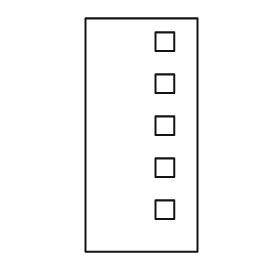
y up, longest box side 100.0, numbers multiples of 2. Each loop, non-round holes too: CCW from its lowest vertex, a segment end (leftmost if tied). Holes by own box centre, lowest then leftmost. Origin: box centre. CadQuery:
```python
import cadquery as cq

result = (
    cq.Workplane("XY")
    .moveTo(-24.0, -50.0)
    .lineTo(24.0, -50.0)
    .lineTo(24.0, 50.0)
    .lineTo(-24.0, 50.0)
    .close()
    .moveTo(6.0, -36.0)
    .lineTo(14.0, -36.0)
    .lineTo(14.0, -28.0)
    .lineTo(6.0, -28.0)
    .close()
    .moveTo(6.0, -18.0)
    .lineTo(14.0, -18.0)
    .lineTo(14.0, -10.0)
    .lineTo(6.0, -10.0)
    .close()
    .moveTo(6.0, 0.0)
    .lineTo(14.0, 0.0)
    .lineTo(14.0, 8.0)
    .lineTo(6.0, 8.0)
    .close()
    .moveTo(6.0, 18.0)
    .lineTo(14.0, 18.0)
    .lineTo(14.0, 26.0)
    .lineTo(6.0, 26.0)
    .close()
    .moveTo(6.0, 36.0)
    .lineTo(14.0, 36.0)
    .lineTo(14.0, 44.0)
    .lineTo(6.0, 44.0)
    .close()
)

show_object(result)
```